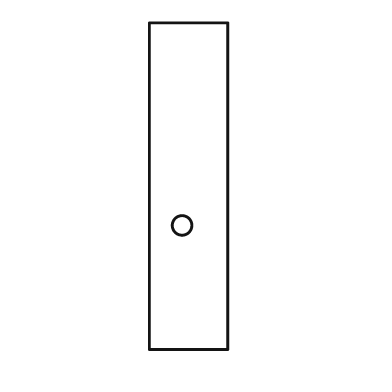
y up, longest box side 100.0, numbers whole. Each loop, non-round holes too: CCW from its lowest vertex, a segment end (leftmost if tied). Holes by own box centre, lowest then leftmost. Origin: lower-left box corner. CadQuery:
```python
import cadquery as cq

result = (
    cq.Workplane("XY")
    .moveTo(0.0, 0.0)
    .lineTo(24.0, 0.0)
    .lineTo(24.0, 100.0)
    .lineTo(0.0, 100.0)
    .close()
    .moveTo(10.0, 38.0)
    .circle(3.0)
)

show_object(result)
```